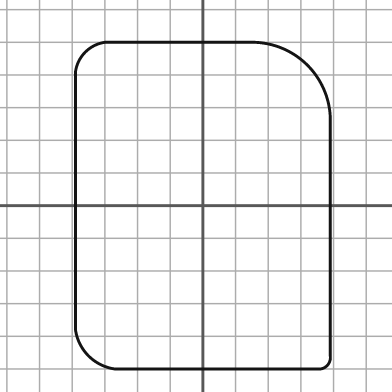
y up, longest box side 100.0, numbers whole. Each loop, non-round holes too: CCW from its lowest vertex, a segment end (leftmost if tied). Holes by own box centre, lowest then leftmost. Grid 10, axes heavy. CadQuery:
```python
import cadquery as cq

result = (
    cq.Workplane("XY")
    .moveTo(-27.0, -50.0)
    .lineTo(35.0, -50.0)
    .threePointArc((38.0, -49.0), (39.0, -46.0))
    .lineTo(39.0, 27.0)
    .threePointArc((32.0, 43.0), (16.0, 50.0))
    .lineTo(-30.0, 50.0)
    .threePointArc((-36.0, 47.0), (-39.0, 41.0))
    .lineTo(-39.0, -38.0)
    .threePointArc((-35.0, -46.0), (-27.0, -50.0))
    .close()
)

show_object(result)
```